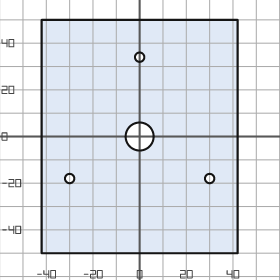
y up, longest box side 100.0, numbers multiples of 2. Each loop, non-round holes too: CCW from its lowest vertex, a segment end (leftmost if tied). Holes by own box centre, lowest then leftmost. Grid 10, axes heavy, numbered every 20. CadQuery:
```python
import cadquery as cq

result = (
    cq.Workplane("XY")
    .moveTo(-42.0, -50.0)
    .lineTo(42.0, -50.0)
    .lineTo(42.0, 50.0)
    .lineTo(-42.0, 50.0)
    .close()
    .moveTo(-30.0, -18.0)
    .circle(2.0)
    .moveTo(30.0, -18.0)
    .circle(2.0)
    .moveTo(0.0, 0.0)
    .circle(6.0)
    .moveTo(0.0, 34.0)
    .circle(2.0)
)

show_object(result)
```